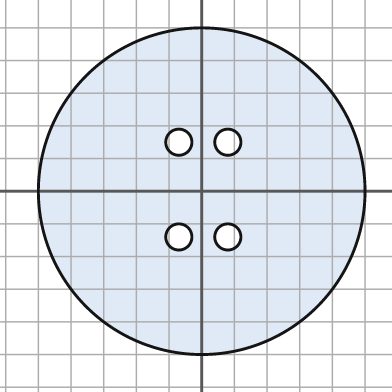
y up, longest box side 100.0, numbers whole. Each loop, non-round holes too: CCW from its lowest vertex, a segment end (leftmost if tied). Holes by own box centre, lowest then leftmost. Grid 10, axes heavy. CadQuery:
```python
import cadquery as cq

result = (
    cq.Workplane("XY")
    .moveTo(0.0, 0.0)
    .circle(50.0)
    .moveTo(-7.0, -14.0)
    .circle(4.0)
    .moveTo(8.0, -14.0)
    .circle(4.0)
    .moveTo(-7.0, 15.0)
    .circle(4.0)
    .moveTo(8.0, 15.0)
    .circle(4.0)
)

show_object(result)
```